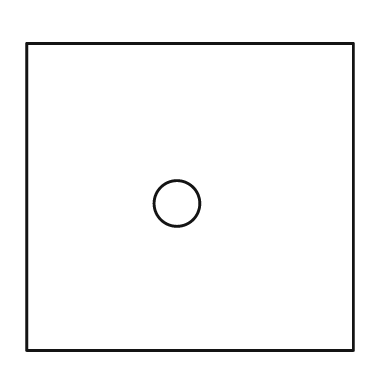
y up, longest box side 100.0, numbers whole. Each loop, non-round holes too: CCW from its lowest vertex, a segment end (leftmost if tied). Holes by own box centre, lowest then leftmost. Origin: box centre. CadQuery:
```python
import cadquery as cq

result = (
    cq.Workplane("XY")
    .moveTo(-50.0, -47.0)
    .lineTo(50.0, -47.0)
    .lineTo(50.0, 47.0)
    .lineTo(-50.0, 47.0)
    .close()
    .moveTo(-4.0, -2.0)
    .circle(7.0)
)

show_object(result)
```